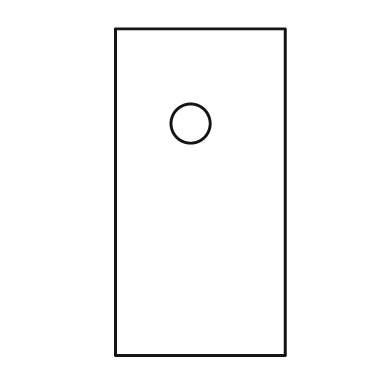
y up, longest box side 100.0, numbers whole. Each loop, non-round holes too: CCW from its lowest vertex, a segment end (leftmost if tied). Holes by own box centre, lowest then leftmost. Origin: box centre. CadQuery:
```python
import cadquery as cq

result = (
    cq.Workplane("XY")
    .moveTo(-26.0, -50.0)
    .lineTo(26.0, -50.0)
    .lineTo(26.0, 50.0)
    .lineTo(-26.0, 50.0)
    .close()
    .moveTo(-3.0, 21.0)
    .circle(6.0)
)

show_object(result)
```